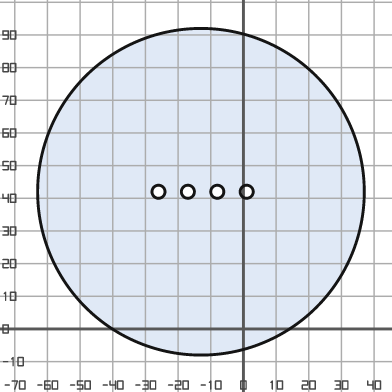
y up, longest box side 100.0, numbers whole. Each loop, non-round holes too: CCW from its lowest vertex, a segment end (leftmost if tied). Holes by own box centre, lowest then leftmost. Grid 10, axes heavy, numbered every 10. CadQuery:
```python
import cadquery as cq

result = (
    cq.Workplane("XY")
    .moveTo(-13.0, 42.0)
    .circle(50.0)
    .moveTo(-26.0, 42.0)
    .circle(2.0)
    .moveTo(-17.0, 42.0)
    .circle(2.0)
    .moveTo(-8.0, 42.0)
    .circle(2.0)
    .moveTo(1.0, 42.0)
    .circle(2.0)
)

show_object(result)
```